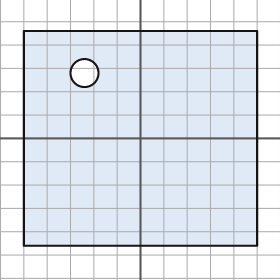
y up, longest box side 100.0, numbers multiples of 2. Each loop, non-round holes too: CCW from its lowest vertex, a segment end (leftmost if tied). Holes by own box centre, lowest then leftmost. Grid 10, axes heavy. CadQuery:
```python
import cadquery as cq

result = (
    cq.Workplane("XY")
    .moveTo(-50.0, -46.0)
    .lineTo(50.0, -46.0)
    .lineTo(50.0, 46.0)
    .lineTo(-50.0, 46.0)
    .close()
    .moveTo(-24.0, 28.0)
    .circle(6.0)
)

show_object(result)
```